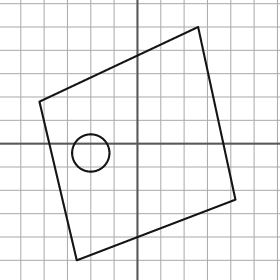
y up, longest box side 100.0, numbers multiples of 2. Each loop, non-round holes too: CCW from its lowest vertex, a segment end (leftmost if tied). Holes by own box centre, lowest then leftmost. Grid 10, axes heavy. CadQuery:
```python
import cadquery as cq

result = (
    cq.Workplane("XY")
    .moveTo(-26.0, -50.0)
    .lineTo(42.0, -24.0)
    .lineTo(26.0, 50.0)
    .lineTo(-42.0, 18.0)
    .close()
    .moveTo(-20.0, -4.0)
    .circle(8.0)
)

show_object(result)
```